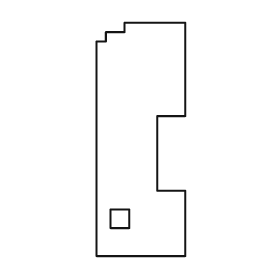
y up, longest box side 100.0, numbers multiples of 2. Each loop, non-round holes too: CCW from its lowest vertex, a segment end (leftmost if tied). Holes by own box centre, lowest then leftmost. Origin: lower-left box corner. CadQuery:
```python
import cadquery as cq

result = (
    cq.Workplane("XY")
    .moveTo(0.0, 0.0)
    .lineTo(38.0, 0.0)
    .lineTo(38.0, 28.0)
    .lineTo(26.0, 28.0)
    .lineTo(26.0, 60.0)
    .lineTo(38.0, 60.0)
    .lineTo(38.0, 100.0)
    .lineTo(12.0, 100.0)
    .lineTo(12.0, 96.0)
    .lineTo(4.0, 96.0)
    .lineTo(4.0, 92.0)
    .lineTo(0.0, 92.0)
    .close()
    .moveTo(6.0, 12.0)
    .lineTo(14.0, 12.0)
    .lineTo(14.0, 20.0)
    .lineTo(6.0, 20.0)
    .close()
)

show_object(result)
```